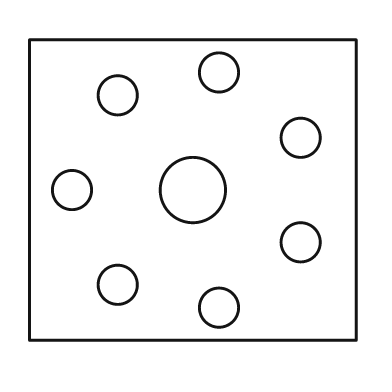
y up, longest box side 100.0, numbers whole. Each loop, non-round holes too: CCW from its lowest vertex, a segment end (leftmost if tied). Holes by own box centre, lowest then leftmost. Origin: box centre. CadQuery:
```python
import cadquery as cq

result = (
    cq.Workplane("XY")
    .moveTo(-50.0, -46.0)
    .lineTo(50.0, -46.0)
    .lineTo(50.0, 46.0)
    .lineTo(-50.0, 46.0)
    .close()
    .moveTo(8.0, -36.0)
    .circle(6.0)
    .moveTo(-23.0, -29.0)
    .circle(6.0)
    .moveTo(33.0, -16.0)
    .circle(6.0)
    .moveTo(-37.0, 0.0)
    .circle(6.0)
    .moveTo(0.0, 0.0)
    .circle(10.0)
    .moveTo(33.0, 16.0)
    .circle(6.0)
    .moveTo(-23.0, 29.0)
    .circle(6.0)
    .moveTo(8.0, 36.0)
    .circle(6.0)
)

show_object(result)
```